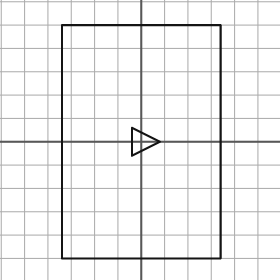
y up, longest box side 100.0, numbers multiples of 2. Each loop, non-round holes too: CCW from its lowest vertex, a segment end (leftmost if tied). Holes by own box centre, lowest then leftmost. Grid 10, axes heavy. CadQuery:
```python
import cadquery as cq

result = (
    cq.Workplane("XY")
    .moveTo(-34.0, -50.0)
    .lineTo(34.0, -50.0)
    .lineTo(34.0, 50.0)
    .lineTo(-34.0, 50.0)
    .close()
    .moveTo(-4.0, -6.0)
    .lineTo(8.0, 0.0)
    .lineTo(-4.0, 6.0)
    .close()
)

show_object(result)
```